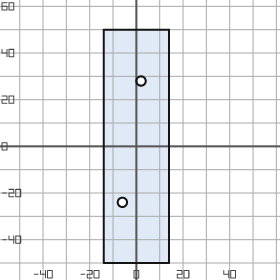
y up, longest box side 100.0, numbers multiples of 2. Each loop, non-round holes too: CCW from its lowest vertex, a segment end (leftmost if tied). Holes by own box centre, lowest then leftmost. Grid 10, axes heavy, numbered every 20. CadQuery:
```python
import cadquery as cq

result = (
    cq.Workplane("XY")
    .moveTo(-14.0, -50.0)
    .lineTo(14.0, -50.0)
    .lineTo(14.0, 50.0)
    .lineTo(-14.0, 50.0)
    .close()
    .moveTo(-6.0, -24.0)
    .circle(2.0)
    .moveTo(2.0, 28.0)
    .circle(2.0)
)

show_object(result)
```